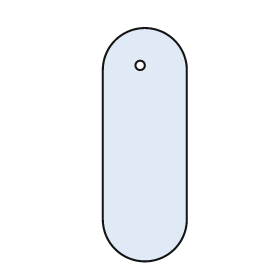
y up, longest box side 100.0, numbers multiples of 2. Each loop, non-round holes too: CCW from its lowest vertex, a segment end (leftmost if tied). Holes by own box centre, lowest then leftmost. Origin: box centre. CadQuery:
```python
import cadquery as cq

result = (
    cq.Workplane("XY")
    .moveTo(-18.0, -32.0)
    .threePointArc((0.0, -50.0), (18.0, -32.0))
    .lineTo(18.0, 32.0)
    .threePointArc((0.0, 50.0), (-18.0, 32.0))
    .close()
    .moveTo(-2.0, 34.0)
    .circle(2.0)
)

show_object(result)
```